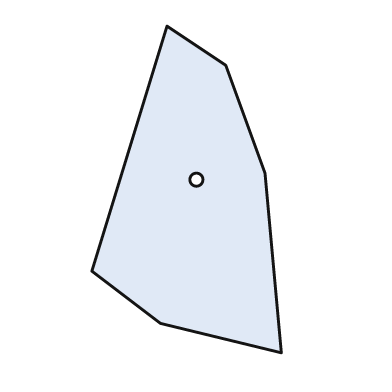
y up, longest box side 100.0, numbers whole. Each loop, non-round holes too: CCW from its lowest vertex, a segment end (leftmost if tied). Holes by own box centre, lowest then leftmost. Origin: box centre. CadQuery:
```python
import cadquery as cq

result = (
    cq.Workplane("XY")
    .moveTo(29.0, -50.0)
    .lineTo(24.0, 5.0)
    .lineTo(12.0, 38.0)
    .lineTo(-6.0, 50.0)
    .lineTo(-29.0, -25.0)
    .lineTo(-8.0, -41.0)
    .close()
    .moveTo(3.0, 3.0)
    .circle(2.0)
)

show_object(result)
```